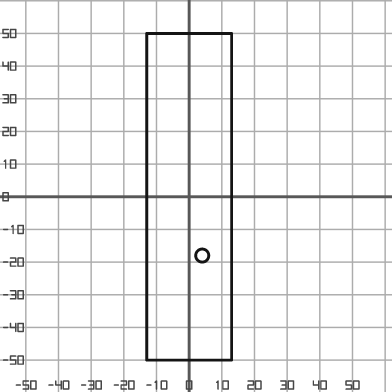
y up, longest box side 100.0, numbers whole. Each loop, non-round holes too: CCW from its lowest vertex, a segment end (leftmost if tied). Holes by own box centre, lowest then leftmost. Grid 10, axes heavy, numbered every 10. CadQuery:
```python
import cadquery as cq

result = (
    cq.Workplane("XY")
    .moveTo(-13.0, -50.0)
    .lineTo(13.0, -50.0)
    .lineTo(13.0, 50.0)
    .lineTo(-13.0, 50.0)
    .close()
    .moveTo(4.0, -18.0)
    .circle(2.0)
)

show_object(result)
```